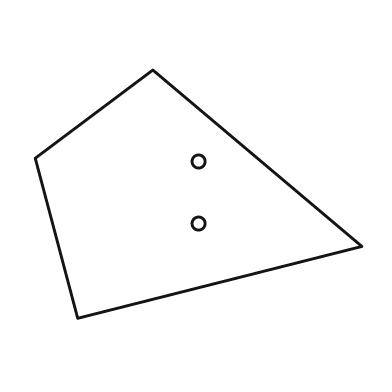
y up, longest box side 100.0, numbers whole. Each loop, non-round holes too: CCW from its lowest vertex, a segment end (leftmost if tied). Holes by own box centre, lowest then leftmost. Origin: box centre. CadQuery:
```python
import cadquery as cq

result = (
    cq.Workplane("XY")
    .moveTo(-37.0, -38.0)
    .lineTo(50.0, -16.0)
    .lineTo(-14.0, 38.0)
    .lineTo(-50.0, 11.0)
    .close()
    .moveTo(0.0, -9.0)
    .circle(2.0)
    .moveTo(0.0, 10.0)
    .circle(2.0)
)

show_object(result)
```